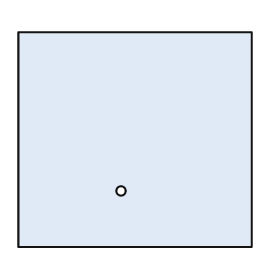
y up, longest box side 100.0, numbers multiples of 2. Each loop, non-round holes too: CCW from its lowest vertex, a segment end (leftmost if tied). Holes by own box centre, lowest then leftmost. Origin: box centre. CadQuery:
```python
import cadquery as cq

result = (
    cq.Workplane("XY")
    .moveTo(-50.0, -46.0)
    .lineTo(50.0, -46.0)
    .lineTo(50.0, 46.0)
    .lineTo(-50.0, 46.0)
    .close()
    .moveTo(-6.0, -22.0)
    .circle(2.0)
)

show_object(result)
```